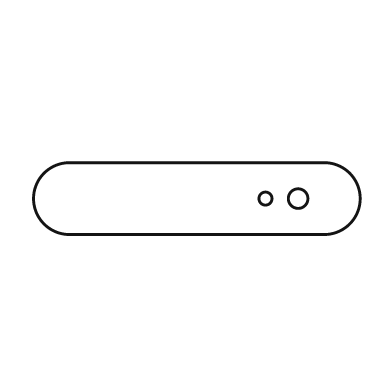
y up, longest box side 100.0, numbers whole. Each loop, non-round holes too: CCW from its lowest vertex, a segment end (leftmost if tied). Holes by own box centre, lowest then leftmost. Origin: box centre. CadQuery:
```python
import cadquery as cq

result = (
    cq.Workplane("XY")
    .moveTo(-39.0, -11.0)
    .lineTo(39.0, -11.0)
    .threePointArc((50.0, 0.0), (39.0, 11.0))
    .lineTo(-39.0, 11.0)
    .threePointArc((-50.0, 0.0), (-39.0, -11.0))
    .close()
    .moveTo(21.0, 0.0)
    .circle(2.0)
    .moveTo(31.0, 0.0)
    .circle(3.0)
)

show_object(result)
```